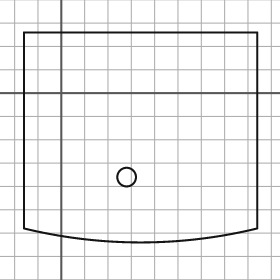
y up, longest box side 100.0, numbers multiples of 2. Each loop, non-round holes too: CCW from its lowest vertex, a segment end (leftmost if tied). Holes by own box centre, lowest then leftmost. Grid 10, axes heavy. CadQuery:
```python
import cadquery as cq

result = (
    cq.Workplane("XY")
    .moveTo(-16.0, -58.0)
    .threePointArc((34.0, -64.0), (84.0, -58.0))
    .lineTo(84.0, 26.0)
    .lineTo(-16.0, 26.0)
    .close()
    .moveTo(28.0, -36.0)
    .circle(4.0)
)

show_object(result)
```